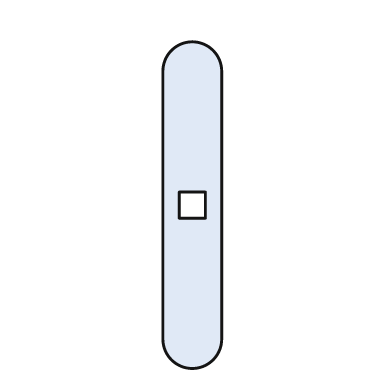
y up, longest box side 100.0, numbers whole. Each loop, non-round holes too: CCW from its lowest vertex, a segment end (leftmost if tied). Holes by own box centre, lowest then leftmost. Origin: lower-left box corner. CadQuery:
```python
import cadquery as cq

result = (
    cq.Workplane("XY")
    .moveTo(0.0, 9.0)
    .threePointArc((9.0, 0.0), (18.0, 9.0))
    .lineTo(18.0, 91.0)
    .threePointArc((9.0, 100.0), (0.0, 91.0))
    .close()
    .moveTo(5.0, 46.0)
    .lineTo(13.0, 46.0)
    .lineTo(13.0, 54.0)
    .lineTo(5.0, 54.0)
    .close()
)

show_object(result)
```